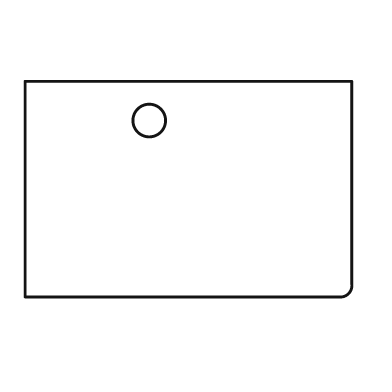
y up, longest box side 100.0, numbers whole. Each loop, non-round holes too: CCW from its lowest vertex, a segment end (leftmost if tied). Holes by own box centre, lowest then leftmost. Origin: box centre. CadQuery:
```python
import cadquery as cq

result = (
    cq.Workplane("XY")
    .moveTo(-50.0, -33.0)
    .lineTo(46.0, -33.0)
    .threePointArc((49.0, -32.0), (50.0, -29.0))
    .lineTo(50.0, 33.0)
    .lineTo(-50.0, 33.0)
    .close()
    .moveTo(-12.0, 21.0)
    .circle(5.0)
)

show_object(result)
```